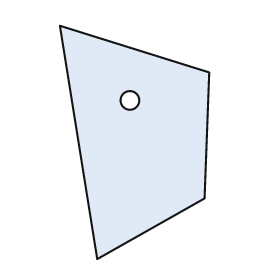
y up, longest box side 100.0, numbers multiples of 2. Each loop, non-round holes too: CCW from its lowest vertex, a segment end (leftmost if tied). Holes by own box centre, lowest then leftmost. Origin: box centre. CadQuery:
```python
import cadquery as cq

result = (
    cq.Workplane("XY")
    .moveTo(-16.0, -50.0)
    .lineTo(30.0, -24.0)
    .lineTo(32.0, 30.0)
    .lineTo(-32.0, 50.0)
    .close()
    .moveTo(-2.0, 18.0)
    .circle(4.0)
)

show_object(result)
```